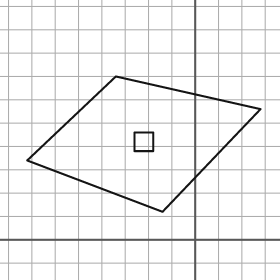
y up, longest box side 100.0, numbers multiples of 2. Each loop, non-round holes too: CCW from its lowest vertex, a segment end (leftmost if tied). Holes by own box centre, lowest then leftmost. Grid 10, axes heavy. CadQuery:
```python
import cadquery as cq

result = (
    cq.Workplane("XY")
    .moveTo(-14.0, 12.0)
    .lineTo(28.0, 56.0)
    .lineTo(-34.0, 70.0)
    .lineTo(-72.0, 34.0)
    .close()
    .moveTo(-26.0, 38.0)
    .lineTo(-18.0, 38.0)
    .lineTo(-18.0, 46.0)
    .lineTo(-26.0, 46.0)
    .close()
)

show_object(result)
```